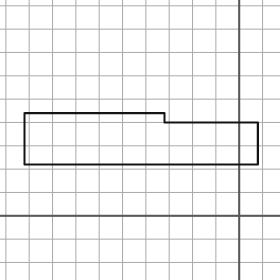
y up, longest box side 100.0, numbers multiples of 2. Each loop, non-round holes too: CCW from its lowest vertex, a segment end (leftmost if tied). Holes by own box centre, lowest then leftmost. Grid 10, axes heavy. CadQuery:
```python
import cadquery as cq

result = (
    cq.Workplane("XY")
    .moveTo(-92.0, 22.0)
    .lineTo(8.0, 22.0)
    .lineTo(8.0, 40.0)
    .lineTo(-32.0, 40.0)
    .lineTo(-32.0, 44.0)
    .lineTo(-92.0, 44.0)
    .close()
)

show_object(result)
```